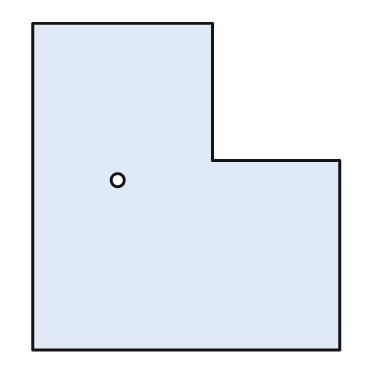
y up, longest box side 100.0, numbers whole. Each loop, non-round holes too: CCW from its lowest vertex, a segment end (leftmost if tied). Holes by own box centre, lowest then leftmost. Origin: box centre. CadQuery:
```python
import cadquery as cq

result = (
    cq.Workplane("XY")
    .moveTo(-47.0, -50.0)
    .lineTo(47.0, -50.0)
    .lineTo(47.0, 8.0)
    .lineTo(8.0, 8.0)
    .lineTo(8.0, 50.0)
    .lineTo(-47.0, 50.0)
    .close()
    .moveTo(-21.0, 2.0)
    .circle(2.0)
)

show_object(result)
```